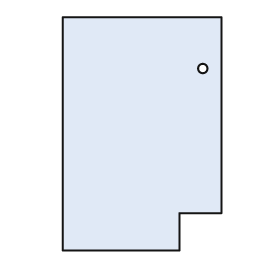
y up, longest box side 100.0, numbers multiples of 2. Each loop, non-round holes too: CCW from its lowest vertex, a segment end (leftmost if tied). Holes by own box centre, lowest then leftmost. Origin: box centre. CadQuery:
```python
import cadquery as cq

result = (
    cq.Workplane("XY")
    .moveTo(-34.0, -50.0)
    .lineTo(16.0, -50.0)
    .lineTo(16.0, -34.0)
    .lineTo(34.0, -34.0)
    .lineTo(34.0, 50.0)
    .lineTo(-34.0, 50.0)
    .close()
    .moveTo(26.0, 28.0)
    .circle(2.0)
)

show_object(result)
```